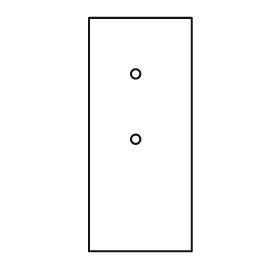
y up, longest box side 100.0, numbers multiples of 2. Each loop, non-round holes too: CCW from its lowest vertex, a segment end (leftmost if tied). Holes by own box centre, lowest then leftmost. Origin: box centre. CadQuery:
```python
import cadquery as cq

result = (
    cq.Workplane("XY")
    .moveTo(-22.0, -50.0)
    .lineTo(22.0, -50.0)
    .lineTo(22.0, 50.0)
    .lineTo(-22.0, 50.0)
    .close()
    .moveTo(-2.0, -2.0)
    .circle(2.0)
    .moveTo(-2.0, 26.0)
    .circle(2.0)
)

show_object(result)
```